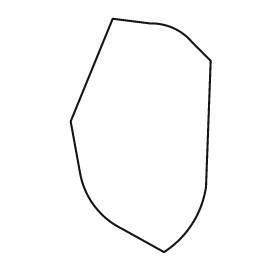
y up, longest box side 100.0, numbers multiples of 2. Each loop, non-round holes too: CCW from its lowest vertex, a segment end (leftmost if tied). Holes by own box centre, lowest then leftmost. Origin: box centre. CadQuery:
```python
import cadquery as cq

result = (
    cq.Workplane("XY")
    .moveTo(10.0, -50.0)
    .threePointArc((22.0, -38.0), (28.0, -22.0))
    .lineTo(30.0, 32.0)
    .lineTo(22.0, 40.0)
    .threePointArc((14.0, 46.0), (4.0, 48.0))
    .lineTo(-12.0, 50.0)
    .lineTo(-30.0, 6.0)
    .lineTo(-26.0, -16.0)
    .threePointArc((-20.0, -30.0), (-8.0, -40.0))
    .close()
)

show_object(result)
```